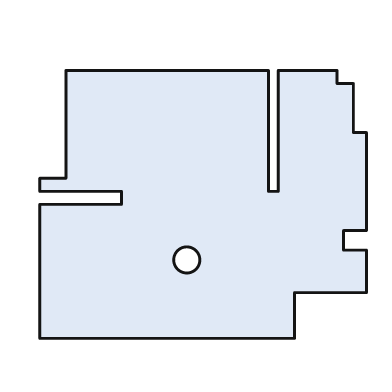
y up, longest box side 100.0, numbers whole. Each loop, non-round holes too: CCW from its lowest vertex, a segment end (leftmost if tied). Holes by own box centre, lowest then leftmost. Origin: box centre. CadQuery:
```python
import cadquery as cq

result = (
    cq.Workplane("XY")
    .moveTo(-50.0, -41.0)
    .lineTo(28.0, -41.0)
    .lineTo(28.0, -27.0)
    .lineTo(50.0, -27.0)
    .lineTo(50.0, -14.0)
    .lineTo(43.0, -14.0)
    .lineTo(43.0, -8.0)
    .lineTo(50.0, -8.0)
    .lineTo(50.0, 22.0)
    .lineTo(46.0, 22.0)
    .lineTo(46.0, 37.0)
    .lineTo(41.0, 37.0)
    .lineTo(41.0, 41.0)
    .lineTo(23.0, 41.0)
    .lineTo(23.0, 4.0)
    .lineTo(20.0, 4.0)
    .lineTo(20.0, 41.0)
    .lineTo(-42.0, 41.0)
    .lineTo(-42.0, 8.0)
    .lineTo(-50.0, 8.0)
    .lineTo(-50.0, 4.0)
    .lineTo(-25.0, 4.0)
    .lineTo(-25.0, 0.0)
    .lineTo(-50.0, 0.0)
    .close()
    .moveTo(-5.0, -17.0)
    .circle(4.0)
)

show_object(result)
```